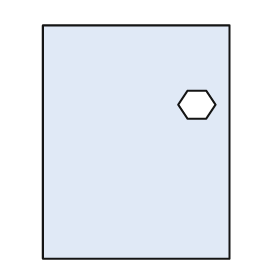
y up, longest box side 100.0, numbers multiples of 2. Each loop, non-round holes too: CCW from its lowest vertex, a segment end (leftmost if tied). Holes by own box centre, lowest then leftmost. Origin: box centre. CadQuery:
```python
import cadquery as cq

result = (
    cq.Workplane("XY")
    .moveTo(-40.0, -50.0)
    .lineTo(40.0, -50.0)
    .lineTo(40.0, 50.0)
    .lineTo(-40.0, 50.0)
    .close()
    .moveTo(22.0, 10.0)
    .lineTo(30.0, 10.0)
    .lineTo(34.0, 16.0)
    .lineTo(30.0, 22.0)
    .lineTo(22.0, 22.0)
    .lineTo(18.0, 16.0)
    .close()
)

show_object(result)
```